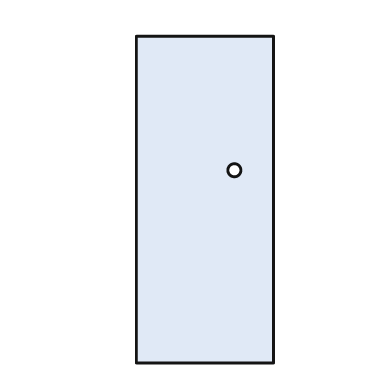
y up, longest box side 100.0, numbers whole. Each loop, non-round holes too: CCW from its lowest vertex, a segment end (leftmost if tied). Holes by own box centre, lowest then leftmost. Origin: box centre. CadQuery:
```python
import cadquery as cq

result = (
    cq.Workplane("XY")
    .moveTo(-21.0, -50.0)
    .lineTo(21.0, -50.0)
    .lineTo(21.0, 50.0)
    .lineTo(-21.0, 50.0)
    .close()
    .moveTo(9.0, 9.0)
    .circle(2.0)
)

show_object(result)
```